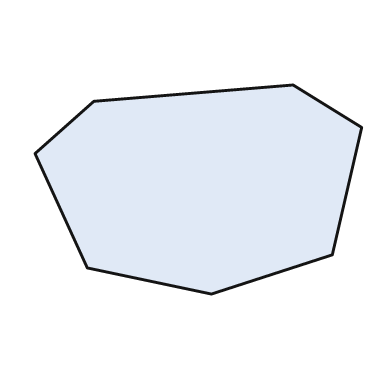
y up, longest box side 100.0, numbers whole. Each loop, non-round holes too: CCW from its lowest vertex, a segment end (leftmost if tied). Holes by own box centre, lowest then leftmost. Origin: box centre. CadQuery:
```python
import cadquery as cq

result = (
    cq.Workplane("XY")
    .moveTo(4.0, -32.0)
    .lineTo(41.0, -20.0)
    .lineTo(50.0, 19.0)
    .lineTo(29.0, 32.0)
    .lineTo(-32.0, 27.0)
    .lineTo(-50.0, 11.0)
    .lineTo(-34.0, -24.0)
    .close()
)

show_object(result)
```